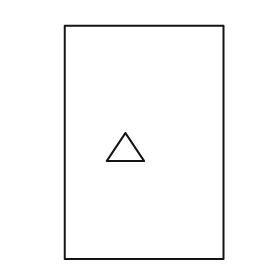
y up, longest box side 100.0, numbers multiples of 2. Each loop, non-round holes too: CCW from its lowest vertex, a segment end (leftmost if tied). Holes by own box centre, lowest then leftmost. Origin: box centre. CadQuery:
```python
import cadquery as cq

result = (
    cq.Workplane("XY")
    .moveTo(-34.0, -50.0)
    .lineTo(34.0, -50.0)
    .lineTo(34.0, 50.0)
    .lineTo(-34.0, 50.0)
    .close()
    .moveTo(-16.0, -8.0)
    .lineTo(0.0, -8.0)
    .lineTo(-8.0, 4.0)
    .close()
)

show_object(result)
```